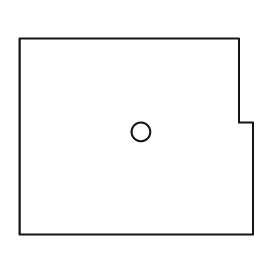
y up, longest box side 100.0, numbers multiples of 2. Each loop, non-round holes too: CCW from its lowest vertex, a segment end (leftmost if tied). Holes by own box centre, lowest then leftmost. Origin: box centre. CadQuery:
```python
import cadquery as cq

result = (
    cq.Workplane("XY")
    .moveTo(-50.0, -42.0)
    .lineTo(50.0, -42.0)
    .lineTo(50.0, 6.0)
    .lineTo(44.0, 6.0)
    .lineTo(44.0, 42.0)
    .lineTo(-50.0, 42.0)
    .close()
    .moveTo(2.0, 2.0)
    .circle(4.0)
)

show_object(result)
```